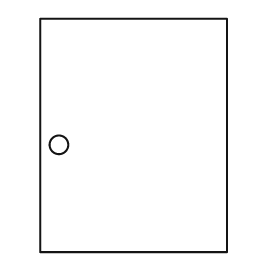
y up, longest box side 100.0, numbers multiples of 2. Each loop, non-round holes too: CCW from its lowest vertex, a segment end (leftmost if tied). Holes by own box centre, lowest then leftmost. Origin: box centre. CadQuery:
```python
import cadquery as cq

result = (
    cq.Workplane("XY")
    .moveTo(-40.0, -50.0)
    .lineTo(40.0, -50.0)
    .lineTo(40.0, 50.0)
    .lineTo(-40.0, 50.0)
    .close()
    .moveTo(-32.0, -4.0)
    .circle(4.0)
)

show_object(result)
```